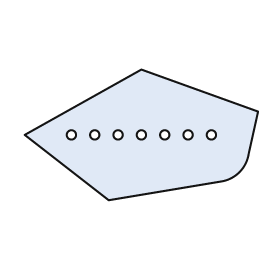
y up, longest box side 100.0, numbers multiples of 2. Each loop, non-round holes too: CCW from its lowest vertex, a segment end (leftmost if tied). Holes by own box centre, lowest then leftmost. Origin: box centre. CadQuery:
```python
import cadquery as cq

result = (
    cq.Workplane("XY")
    .moveTo(-14.0, -28.0)
    .lineTo(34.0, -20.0)
    .threePointArc((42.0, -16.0), (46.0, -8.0))
    .lineTo(50.0, 10.0)
    .lineTo(0.0, 28.0)
    .lineTo(-50.0, 0.0)
    .close()
    .moveTo(-30.0, 0.0)
    .circle(2.0)
    .moveTo(-20.0, 0.0)
    .circle(2.0)
    .moveTo(-10.0, 0.0)
    .circle(2.0)
    .moveTo(0.0, 0.0)
    .circle(2.0)
    .moveTo(10.0, 0.0)
    .circle(2.0)
    .moveTo(20.0, 0.0)
    .circle(2.0)
    .moveTo(30.0, 0.0)
    .circle(2.0)
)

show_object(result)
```